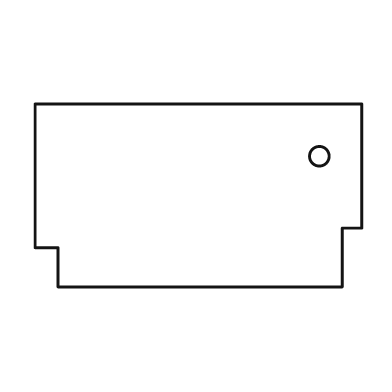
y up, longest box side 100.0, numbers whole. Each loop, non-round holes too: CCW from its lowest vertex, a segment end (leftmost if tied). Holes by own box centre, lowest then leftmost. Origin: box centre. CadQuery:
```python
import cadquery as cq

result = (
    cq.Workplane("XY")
    .moveTo(-43.0, -28.0)
    .lineTo(44.0, -28.0)
    .lineTo(44.0, -10.0)
    .lineTo(50.0, -10.0)
    .lineTo(50.0, 28.0)
    .lineTo(-50.0, 28.0)
    .lineTo(-50.0, -16.0)
    .lineTo(-43.0, -16.0)
    .close()
    .moveTo(37.0, 12.0)
    .circle(3.0)
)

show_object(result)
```